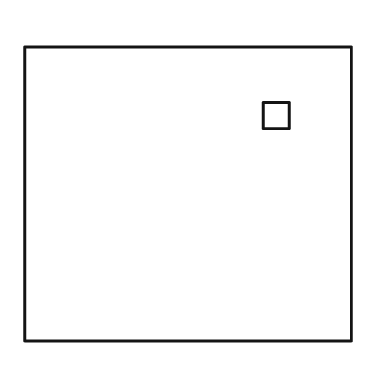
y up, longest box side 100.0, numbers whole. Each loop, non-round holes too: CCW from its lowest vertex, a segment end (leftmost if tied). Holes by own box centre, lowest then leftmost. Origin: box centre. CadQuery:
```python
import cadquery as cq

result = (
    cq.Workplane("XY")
    .moveTo(-50.0, -45.0)
    .lineTo(50.0, -45.0)
    .lineTo(50.0, 45.0)
    .lineTo(-50.0, 45.0)
    .close()
    .moveTo(23.0, 20.0)
    .lineTo(31.0, 20.0)
    .lineTo(31.0, 28.0)
    .lineTo(23.0, 28.0)
    .close()
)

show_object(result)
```